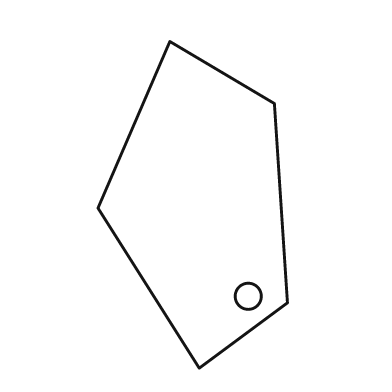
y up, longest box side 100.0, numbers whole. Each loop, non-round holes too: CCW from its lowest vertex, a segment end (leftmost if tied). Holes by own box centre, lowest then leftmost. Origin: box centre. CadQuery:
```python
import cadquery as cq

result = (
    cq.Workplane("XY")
    .moveTo(2.0, -50.0)
    .lineTo(29.0, -30.0)
    .lineTo(25.0, 31.0)
    .lineTo(-7.0, 50.0)
    .lineTo(-29.0, -1.0)
    .close()
    .moveTo(17.0, -28.0)
    .circle(4.0)
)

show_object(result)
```